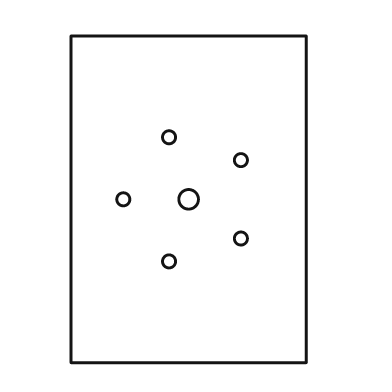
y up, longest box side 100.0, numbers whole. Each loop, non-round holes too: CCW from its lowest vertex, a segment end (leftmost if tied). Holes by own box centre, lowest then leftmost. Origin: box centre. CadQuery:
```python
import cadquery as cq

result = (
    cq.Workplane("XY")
    .moveTo(-36.0, -50.0)
    .lineTo(36.0, -50.0)
    .lineTo(36.0, 50.0)
    .lineTo(-36.0, 50.0)
    .close()
    .moveTo(-6.0, -19.0)
    .circle(2.0)
    .moveTo(16.0, -12.0)
    .circle(2.0)
    .moveTo(-20.0, 0.0)
    .circle(2.0)
    .moveTo(0.0, 0.0)
    .circle(3.0)
    .moveTo(16.0, 12.0)
    .circle(2.0)
    .moveTo(-6.0, 19.0)
    .circle(2.0)
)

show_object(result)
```